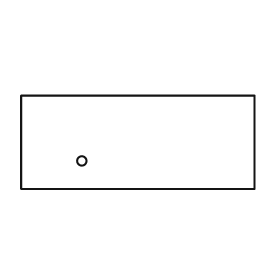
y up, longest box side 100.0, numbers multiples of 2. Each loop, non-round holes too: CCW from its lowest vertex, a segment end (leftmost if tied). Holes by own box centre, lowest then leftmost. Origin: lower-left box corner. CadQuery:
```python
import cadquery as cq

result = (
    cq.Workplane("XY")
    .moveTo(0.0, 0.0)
    .lineTo(100.0, 0.0)
    .lineTo(100.0, 40.0)
    .lineTo(0.0, 40.0)
    .close()
    .moveTo(26.0, 12.0)
    .circle(2.0)
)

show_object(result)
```